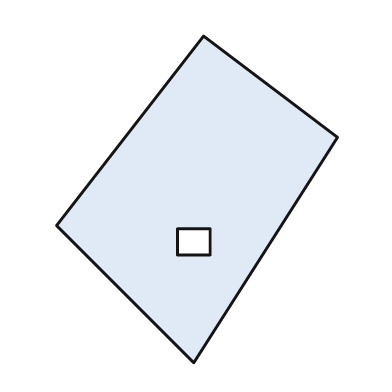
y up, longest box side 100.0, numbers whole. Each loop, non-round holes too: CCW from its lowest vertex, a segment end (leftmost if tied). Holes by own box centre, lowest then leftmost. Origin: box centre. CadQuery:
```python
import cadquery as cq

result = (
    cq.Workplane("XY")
    .moveTo(-1.0, -50.0)
    .lineTo(43.0, 19.0)
    .lineTo(2.0, 50.0)
    .lineTo(-43.0, -8.0)
    .close()
    .moveTo(-6.0, -17.0)
    .lineTo(4.0, -17.0)
    .lineTo(4.0, -9.0)
    .lineTo(-6.0, -9.0)
    .close()
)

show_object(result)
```